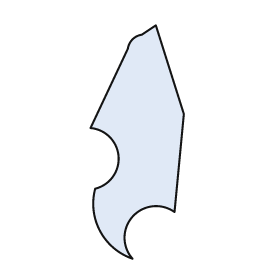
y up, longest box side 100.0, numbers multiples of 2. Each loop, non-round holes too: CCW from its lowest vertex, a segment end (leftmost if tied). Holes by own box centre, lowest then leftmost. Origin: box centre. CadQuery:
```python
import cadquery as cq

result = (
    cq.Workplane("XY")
    .moveTo(-2.0, -50.0)
    .threePointArc((-2.0, -32.0), (16.0, -30.0))
    .lineTo(20.0, 12.0)
    .lineTo(8.0, 50.0)
    .lineTo(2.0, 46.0)
    .threePointArc((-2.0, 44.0), (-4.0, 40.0))
    .lineTo(-20.0, 6.0)
    .threePointArc((-8.0, -6.0), (-18.0, -20.0))
    .threePointArc((-16.0, -38.0), (-2.0, -50.0))
    .close()
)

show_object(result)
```